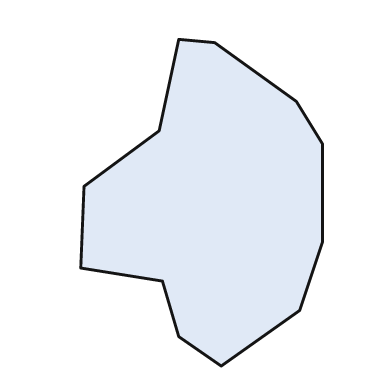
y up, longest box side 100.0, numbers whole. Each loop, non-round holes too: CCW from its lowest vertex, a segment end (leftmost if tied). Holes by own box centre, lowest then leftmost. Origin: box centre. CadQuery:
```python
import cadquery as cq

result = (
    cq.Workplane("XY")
    .moveTo(6.0, -50.0)
    .lineTo(30.0, -33.0)
    .lineTo(37.0, -12.0)
    .lineTo(37.0, 18.0)
    .lineTo(29.0, 31.0)
    .lineTo(4.0, 49.0)
    .lineTo(-7.0, 50.0)
    .lineTo(-13.0, 22.0)
    .lineTo(-36.0, 5.0)
    .lineTo(-37.0, -20.0)
    .lineTo(-12.0, -24.0)
    .lineTo(-7.0, -41.0)
    .close()
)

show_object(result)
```